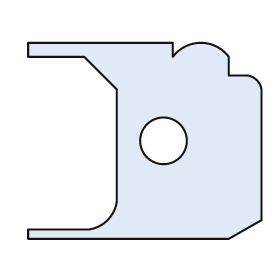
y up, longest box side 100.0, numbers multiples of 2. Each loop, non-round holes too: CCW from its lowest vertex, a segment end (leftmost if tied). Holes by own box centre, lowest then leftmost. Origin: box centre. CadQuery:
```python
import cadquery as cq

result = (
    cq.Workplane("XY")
    .moveTo(-50.0, -42.0)
    .lineTo(36.0, -42.0)
    .lineTo(50.0, -34.0)
    .lineTo(50.0, 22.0)
    .threePointArc((48.0, 26.0), (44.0, 28.0))
    .lineTo(36.0, 28.0)
    .lineTo(36.0, 36.0)
    .threePointArc((24.0, 42.0), (12.0, 36.0))
    .lineTo(12.0, 42.0)
    .lineTo(-50.0, 42.0)
    .lineTo(-50.0, 36.0)
    .lineTo(-26.0, 36.0)
    .lineTo(-12.0, 22.0)
    .lineTo(-12.0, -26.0)
    .threePointArc((-16.0, -34.0), (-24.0, -38.0))
    .lineTo(-50.0, -38.0)
    .close()
    .moveTo(8.0, 0.0)
    .circle(10.0)
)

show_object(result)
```